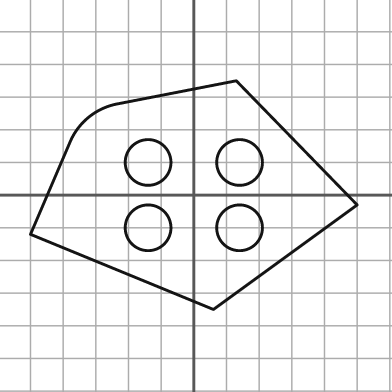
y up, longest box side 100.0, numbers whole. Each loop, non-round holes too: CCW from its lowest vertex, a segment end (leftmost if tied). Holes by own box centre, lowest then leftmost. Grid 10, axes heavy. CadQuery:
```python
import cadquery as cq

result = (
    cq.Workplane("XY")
    .moveTo(6.0, -35.0)
    .lineTo(50.0, -3.0)
    .lineTo(13.0, 35.0)
    .lineTo(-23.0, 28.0)
    .threePointArc((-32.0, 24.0), (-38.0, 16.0))
    .lineTo(-50.0, -12.0)
    .close()
    .moveTo(-14.0, -10.0)
    .circle(7.0)
    .moveTo(14.0, -10.0)
    .circle(7.0)
    .moveTo(-14.0, 10.0)
    .circle(7.0)
    .moveTo(14.0, 10.0)
    .circle(7.0)
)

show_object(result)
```